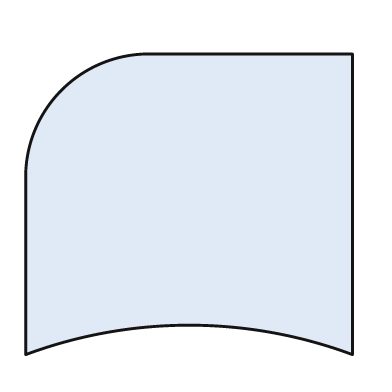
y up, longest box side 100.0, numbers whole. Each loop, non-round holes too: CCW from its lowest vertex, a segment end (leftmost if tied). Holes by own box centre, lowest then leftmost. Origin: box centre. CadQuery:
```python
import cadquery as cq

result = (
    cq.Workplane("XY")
    .moveTo(-50.0, -46.0)
    .threePointArc((0.0, -37.0), (50.0, -46.0))
    .lineTo(50.0, 46.0)
    .lineTo(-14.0, 46.0)
    .threePointArc((-39.0, 35.0), (-50.0, 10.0))
    .close()
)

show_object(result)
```